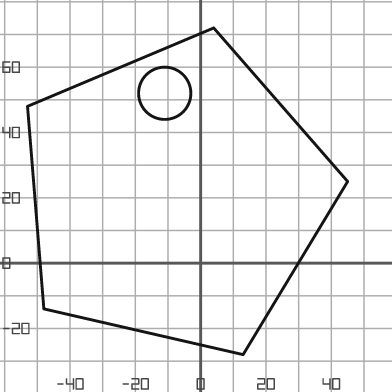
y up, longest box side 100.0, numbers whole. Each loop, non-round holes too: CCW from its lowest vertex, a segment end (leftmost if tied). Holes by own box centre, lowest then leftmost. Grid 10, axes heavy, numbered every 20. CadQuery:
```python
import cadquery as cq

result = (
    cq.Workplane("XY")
    .moveTo(13.0, -28.0)
    .lineTo(45.0, 25.0)
    .lineTo(4.0, 72.0)
    .lineTo(-53.0, 48.0)
    .lineTo(-48.0, -14.0)
    .close()
    .moveTo(-11.0, 52.0)
    .circle(8.0)
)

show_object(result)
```